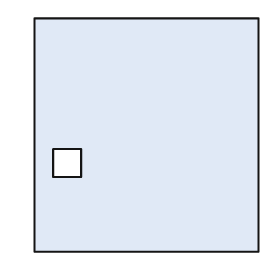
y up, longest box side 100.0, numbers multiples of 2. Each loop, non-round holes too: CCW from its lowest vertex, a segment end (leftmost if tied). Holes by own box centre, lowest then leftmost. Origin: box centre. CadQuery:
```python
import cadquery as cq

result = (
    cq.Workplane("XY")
    .moveTo(-48.0, -50.0)
    .lineTo(48.0, -50.0)
    .lineTo(48.0, 50.0)
    .lineTo(-48.0, 50.0)
    .close()
    .moveTo(-40.0, -18.0)
    .lineTo(-28.0, -18.0)
    .lineTo(-28.0, -6.0)
    .lineTo(-40.0, -6.0)
    .close()
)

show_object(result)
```